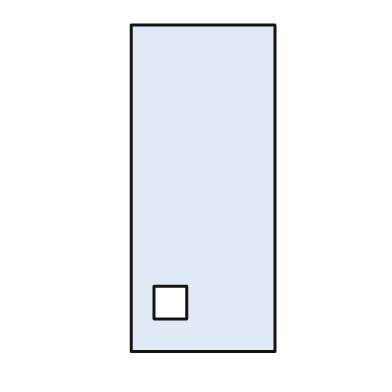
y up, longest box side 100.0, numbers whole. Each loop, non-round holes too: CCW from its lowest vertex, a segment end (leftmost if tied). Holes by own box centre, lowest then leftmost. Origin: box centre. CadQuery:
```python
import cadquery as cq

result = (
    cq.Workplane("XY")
    .moveTo(-22.0, -50.0)
    .lineTo(22.0, -50.0)
    .lineTo(22.0, 50.0)
    .lineTo(-22.0, 50.0)
    .close()
    .moveTo(-15.0, -40.0)
    .lineTo(-5.0, -40.0)
    .lineTo(-5.0, -30.0)
    .lineTo(-15.0, -30.0)
    .close()
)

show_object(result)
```